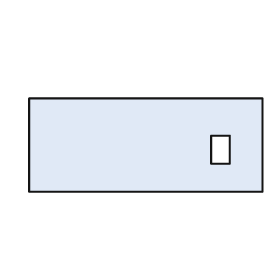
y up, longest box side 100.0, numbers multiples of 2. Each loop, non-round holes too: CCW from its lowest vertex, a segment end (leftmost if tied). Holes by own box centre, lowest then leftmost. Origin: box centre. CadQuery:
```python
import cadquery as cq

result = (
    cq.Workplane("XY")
    .moveTo(-50.0, -20.0)
    .lineTo(50.0, -20.0)
    .lineTo(50.0, 20.0)
    .lineTo(-50.0, 20.0)
    .close()
    .moveTo(28.0, -8.0)
    .lineTo(36.0, -8.0)
    .lineTo(36.0, 4.0)
    .lineTo(28.0, 4.0)
    .close()
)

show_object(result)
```